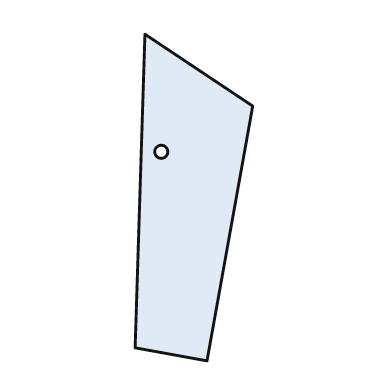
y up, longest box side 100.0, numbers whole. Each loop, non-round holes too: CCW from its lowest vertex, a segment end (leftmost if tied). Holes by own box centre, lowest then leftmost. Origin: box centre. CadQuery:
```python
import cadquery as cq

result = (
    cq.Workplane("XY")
    .moveTo(4.0, -50.0)
    .lineTo(18.0, 28.0)
    .lineTo(-15.0, 50.0)
    .lineTo(-18.0, -46.0)
    .close()
    .moveTo(-10.0, 14.0)
    .circle(2.0)
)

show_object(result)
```